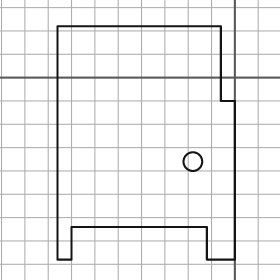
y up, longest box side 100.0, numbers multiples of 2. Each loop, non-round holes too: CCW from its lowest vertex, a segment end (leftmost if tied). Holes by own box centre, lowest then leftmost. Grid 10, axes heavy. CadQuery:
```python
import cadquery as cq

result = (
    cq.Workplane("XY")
    .moveTo(-76.0, -78.0)
    .lineTo(-70.0, -78.0)
    .lineTo(-70.0, -64.0)
    .lineTo(-12.0, -64.0)
    .lineTo(-12.0, -78.0)
    .lineTo(0.0, -78.0)
    .lineTo(0.0, -10.0)
    .lineTo(-6.0, -10.0)
    .lineTo(-6.0, 22.0)
    .lineTo(-76.0, 22.0)
    .close()
    .moveTo(-18.0, -36.0)
    .circle(4.0)
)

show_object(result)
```